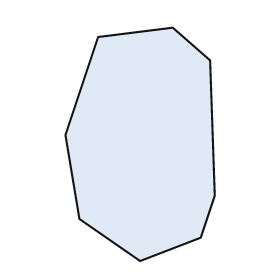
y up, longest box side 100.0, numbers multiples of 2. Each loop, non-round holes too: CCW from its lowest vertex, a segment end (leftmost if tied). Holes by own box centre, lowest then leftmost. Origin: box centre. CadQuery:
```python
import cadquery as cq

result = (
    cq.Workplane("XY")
    .moveTo(0.0, -50.0)
    .lineTo(26.0, -40.0)
    .lineTo(32.0, -22.0)
    .lineTo(30.0, 36.0)
    .lineTo(14.0, 50.0)
    .lineTo(-18.0, 46.0)
    .lineTo(-32.0, 4.0)
    .lineTo(-26.0, -32.0)
    .close()
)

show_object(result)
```